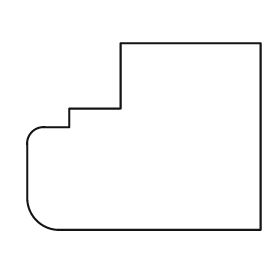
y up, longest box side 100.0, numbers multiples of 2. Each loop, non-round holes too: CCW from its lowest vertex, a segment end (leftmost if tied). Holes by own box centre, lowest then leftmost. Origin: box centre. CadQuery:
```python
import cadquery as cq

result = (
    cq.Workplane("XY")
    .moveTo(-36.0, -40.0)
    .lineTo(50.0, -40.0)
    .lineTo(50.0, 40.0)
    .lineTo(-10.0, 40.0)
    .lineTo(-10.0, 12.0)
    .lineTo(-32.0, 12.0)
    .lineTo(-32.0, 4.0)
    .lineTo(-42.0, 4.0)
    .threePointArc((-48.0, 2.0), (-50.0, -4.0))
    .lineTo(-50.0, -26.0)
    .threePointArc((-46.0, -36.0), (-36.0, -40.0))
    .close()
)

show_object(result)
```